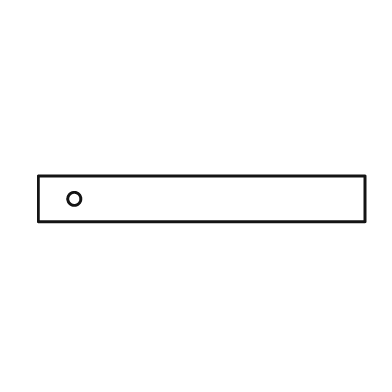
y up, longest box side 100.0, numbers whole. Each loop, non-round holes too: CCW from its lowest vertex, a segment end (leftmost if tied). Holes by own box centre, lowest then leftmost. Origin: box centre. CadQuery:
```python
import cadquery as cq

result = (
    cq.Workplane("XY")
    .moveTo(-50.0, -7.0)
    .lineTo(50.0, -7.0)
    .lineTo(50.0, 7.0)
    .lineTo(-50.0, 7.0)
    .close()
    .moveTo(-39.0, 0.0)
    .circle(2.0)
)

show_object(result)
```